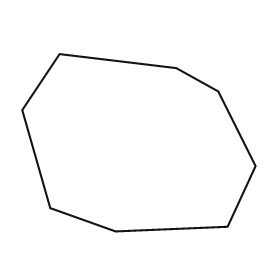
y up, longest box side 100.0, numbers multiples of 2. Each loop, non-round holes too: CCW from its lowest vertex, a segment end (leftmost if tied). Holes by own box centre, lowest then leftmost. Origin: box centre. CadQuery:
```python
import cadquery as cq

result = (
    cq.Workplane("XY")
    .moveTo(-10.0, -38.0)
    .lineTo(38.0, -36.0)
    .lineTo(50.0, -10.0)
    .lineTo(34.0, 22.0)
    .lineTo(16.0, 32.0)
    .lineTo(-34.0, 38.0)
    .lineTo(-50.0, 14.0)
    .lineTo(-38.0, -28.0)
    .close()
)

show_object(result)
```